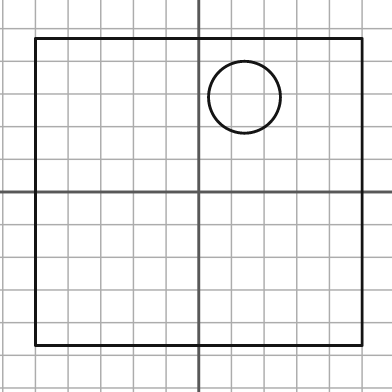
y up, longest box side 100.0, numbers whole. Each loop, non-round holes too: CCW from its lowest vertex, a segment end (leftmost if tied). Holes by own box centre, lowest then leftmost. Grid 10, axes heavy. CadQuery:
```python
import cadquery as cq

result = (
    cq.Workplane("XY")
    .moveTo(-50.0, -47.0)
    .lineTo(50.0, -47.0)
    .lineTo(50.0, 47.0)
    .lineTo(-50.0, 47.0)
    .close()
    .moveTo(14.0, 29.0)
    .circle(11.0)
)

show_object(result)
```